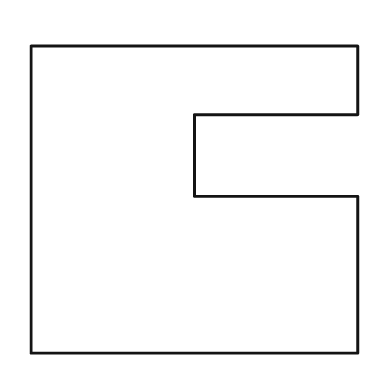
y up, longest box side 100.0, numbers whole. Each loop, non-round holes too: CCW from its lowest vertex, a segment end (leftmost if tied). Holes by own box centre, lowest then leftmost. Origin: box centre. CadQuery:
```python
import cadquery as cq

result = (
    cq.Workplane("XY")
    .moveTo(-50.0, -47.0)
    .lineTo(50.0, -47.0)
    .lineTo(50.0, 1.0)
    .lineTo(0.0, 1.0)
    .lineTo(0.0, 26.0)
    .lineTo(50.0, 26.0)
    .lineTo(50.0, 47.0)
    .lineTo(-50.0, 47.0)
    .close()
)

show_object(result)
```